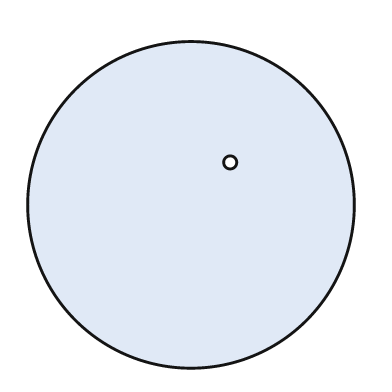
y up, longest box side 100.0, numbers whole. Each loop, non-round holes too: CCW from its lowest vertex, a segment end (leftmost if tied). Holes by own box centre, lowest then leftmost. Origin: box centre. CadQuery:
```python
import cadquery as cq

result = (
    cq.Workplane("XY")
    .moveTo(0.0, 0.0)
    .circle(50.0)
    .moveTo(12.0, 13.0)
    .circle(2.0)
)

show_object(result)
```